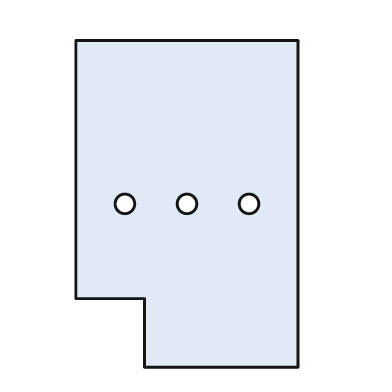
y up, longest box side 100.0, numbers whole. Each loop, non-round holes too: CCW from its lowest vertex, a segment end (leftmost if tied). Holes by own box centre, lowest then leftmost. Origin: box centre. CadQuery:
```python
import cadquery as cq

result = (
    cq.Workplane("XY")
    .moveTo(-13.0, -50.0)
    .lineTo(34.0, -50.0)
    .lineTo(34.0, 50.0)
    .lineTo(-34.0, 50.0)
    .lineTo(-34.0, -29.0)
    .lineTo(-13.0, -29.0)
    .close()
    .moveTo(-19.0, 0.0)
    .circle(3.0)
    .moveTo(0.0, 0.0)
    .circle(3.0)
    .moveTo(19.0, 0.0)
    .circle(3.0)
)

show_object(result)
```